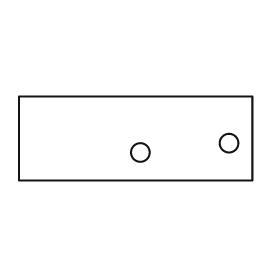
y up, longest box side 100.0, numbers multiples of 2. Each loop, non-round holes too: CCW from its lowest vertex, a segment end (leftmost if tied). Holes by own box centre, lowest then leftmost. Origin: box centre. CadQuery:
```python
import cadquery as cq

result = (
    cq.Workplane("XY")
    .moveTo(-50.0, -18.0)
    .lineTo(50.0, -18.0)
    .lineTo(50.0, 18.0)
    .lineTo(-50.0, 18.0)
    .close()
    .moveTo(2.0, -6.0)
    .circle(4.0)
    .moveTo(40.0, -2.0)
    .circle(4.0)
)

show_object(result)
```